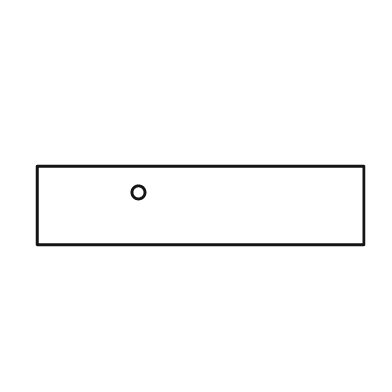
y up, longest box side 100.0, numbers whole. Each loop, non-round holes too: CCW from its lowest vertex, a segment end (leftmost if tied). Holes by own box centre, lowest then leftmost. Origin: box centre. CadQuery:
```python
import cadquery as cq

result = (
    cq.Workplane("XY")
    .moveTo(-50.0, -12.0)
    .lineTo(50.0, -12.0)
    .lineTo(50.0, 12.0)
    .lineTo(-50.0, 12.0)
    .close()
    .moveTo(-19.0, 4.0)
    .circle(2.0)
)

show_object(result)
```